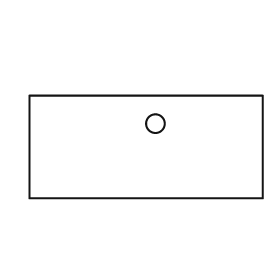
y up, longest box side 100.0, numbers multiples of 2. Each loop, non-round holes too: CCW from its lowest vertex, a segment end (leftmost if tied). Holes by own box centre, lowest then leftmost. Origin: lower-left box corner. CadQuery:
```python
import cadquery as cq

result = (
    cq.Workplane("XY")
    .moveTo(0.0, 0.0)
    .lineTo(100.0, 0.0)
    .lineTo(100.0, 44.0)
    .lineTo(0.0, 44.0)
    .close()
    .moveTo(54.0, 32.0)
    .circle(4.0)
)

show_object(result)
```